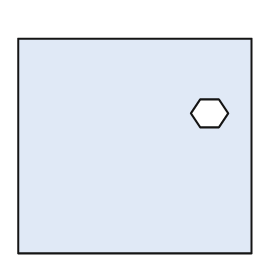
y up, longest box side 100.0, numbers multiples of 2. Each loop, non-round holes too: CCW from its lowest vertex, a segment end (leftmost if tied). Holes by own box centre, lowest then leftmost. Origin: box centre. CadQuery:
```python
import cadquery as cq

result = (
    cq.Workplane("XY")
    .moveTo(-50.0, -46.0)
    .lineTo(50.0, -46.0)
    .lineTo(50.0, 46.0)
    .lineTo(-50.0, 46.0)
    .close()
    .moveTo(28.0, 8.0)
    .lineTo(36.0, 8.0)
    .lineTo(40.0, 14.0)
    .lineTo(36.0, 20.0)
    .lineTo(28.0, 20.0)
    .lineTo(24.0, 14.0)
    .close()
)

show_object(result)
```